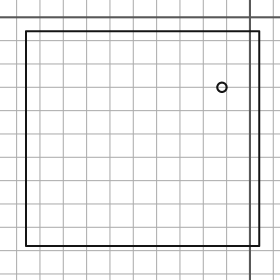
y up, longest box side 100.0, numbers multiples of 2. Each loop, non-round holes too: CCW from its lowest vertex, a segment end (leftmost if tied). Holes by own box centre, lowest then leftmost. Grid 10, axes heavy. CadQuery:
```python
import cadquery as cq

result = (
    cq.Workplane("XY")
    .moveTo(-96.0, -98.0)
    .lineTo(4.0, -98.0)
    .lineTo(4.0, -6.0)
    .lineTo(-96.0, -6.0)
    .close()
    .moveTo(-12.0, -30.0)
    .circle(2.0)
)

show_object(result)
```